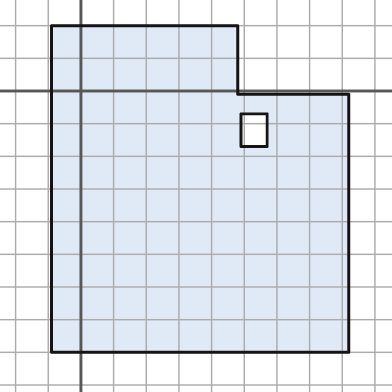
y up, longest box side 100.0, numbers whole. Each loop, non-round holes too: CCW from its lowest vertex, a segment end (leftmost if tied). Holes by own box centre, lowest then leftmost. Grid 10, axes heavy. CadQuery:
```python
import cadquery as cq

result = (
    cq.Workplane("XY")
    .moveTo(-9.0, -80.0)
    .lineTo(82.0, -80.0)
    .lineTo(82.0, -1.0)
    .lineTo(48.0, -1.0)
    .lineTo(48.0, 20.0)
    .lineTo(-9.0, 20.0)
    .close()
    .moveTo(49.0, -17.0)
    .lineTo(57.0, -17.0)
    .lineTo(57.0, -7.0)
    .lineTo(49.0, -7.0)
    .close()
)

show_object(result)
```